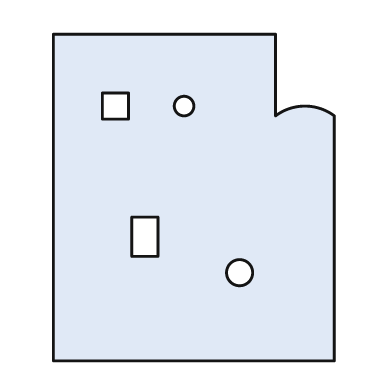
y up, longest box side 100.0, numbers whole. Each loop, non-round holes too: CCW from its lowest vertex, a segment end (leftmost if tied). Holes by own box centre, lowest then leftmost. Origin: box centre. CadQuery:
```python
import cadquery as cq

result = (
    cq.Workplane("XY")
    .moveTo(-43.0, -50.0)
    .lineTo(43.0, -50.0)
    .lineTo(43.0, 25.0)
    .threePointArc((34.0, 28.0), (25.0, 25.0))
    .lineTo(25.0, 50.0)
    .lineTo(-43.0, 50.0)
    .close()
    .moveTo(14.0, -23.0)
    .circle(4.0)
    .moveTo(-19.0, -18.0)
    .lineTo(-11.0, -18.0)
    .lineTo(-11.0, -6.0)
    .lineTo(-19.0, -6.0)
    .close()
    .moveTo(-28.0, 24.0)
    .lineTo(-20.0, 24.0)
    .lineTo(-20.0, 32.0)
    .lineTo(-28.0, 32.0)
    .close()
    .moveTo(-3.0, 28.0)
    .circle(3.0)
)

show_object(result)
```